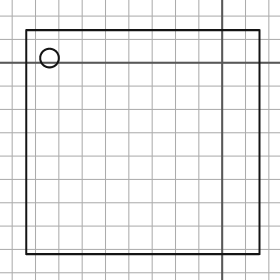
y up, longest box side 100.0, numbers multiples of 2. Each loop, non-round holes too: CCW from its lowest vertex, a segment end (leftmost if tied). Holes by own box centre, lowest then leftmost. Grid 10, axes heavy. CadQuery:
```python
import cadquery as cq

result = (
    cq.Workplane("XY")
    .moveTo(-84.0, -82.0)
    .lineTo(16.0, -82.0)
    .lineTo(16.0, 14.0)
    .lineTo(-84.0, 14.0)
    .close()
    .moveTo(-74.0, 2.0)
    .circle(4.0)
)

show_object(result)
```